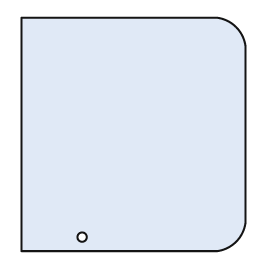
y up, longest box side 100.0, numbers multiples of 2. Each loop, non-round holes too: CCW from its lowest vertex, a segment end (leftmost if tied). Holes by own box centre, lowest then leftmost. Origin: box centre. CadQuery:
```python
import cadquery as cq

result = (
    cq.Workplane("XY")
    .moveTo(-48.0, -50.0)
    .lineTo(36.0, -50.0)
    .threePointArc((44.0, -46.0), (48.0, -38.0))
    .lineTo(48.0, 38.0)
    .threePointArc((44.0, 46.0), (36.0, 50.0))
    .lineTo(-48.0, 50.0)
    .close()
    .moveTo(-22.0, -44.0)
    .circle(2.0)
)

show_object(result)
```